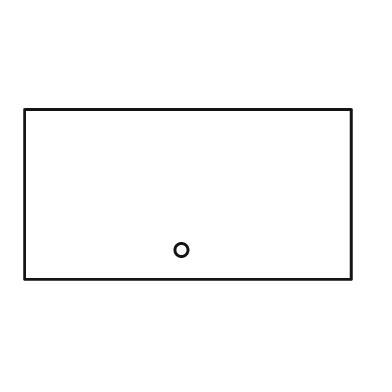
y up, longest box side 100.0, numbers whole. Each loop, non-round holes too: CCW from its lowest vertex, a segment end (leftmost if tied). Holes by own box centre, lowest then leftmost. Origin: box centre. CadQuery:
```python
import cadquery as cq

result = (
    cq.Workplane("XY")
    .moveTo(-50.0, -26.0)
    .lineTo(50.0, -26.0)
    .lineTo(50.0, 26.0)
    .lineTo(-50.0, 26.0)
    .close()
    .moveTo(-2.0, -17.0)
    .circle(2.0)
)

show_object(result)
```